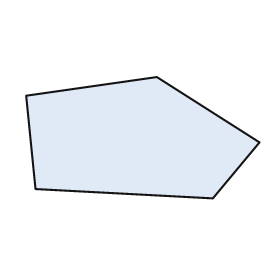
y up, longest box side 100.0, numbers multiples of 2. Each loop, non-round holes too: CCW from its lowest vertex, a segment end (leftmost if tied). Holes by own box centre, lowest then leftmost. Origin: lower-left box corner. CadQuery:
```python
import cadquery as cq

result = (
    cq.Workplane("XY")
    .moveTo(80.0, 0.0)
    .lineTo(100.0, 24.0)
    .lineTo(56.0, 52.0)
    .lineTo(0.0, 44.0)
    .lineTo(4.0, 4.0)
    .close()
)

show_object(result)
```